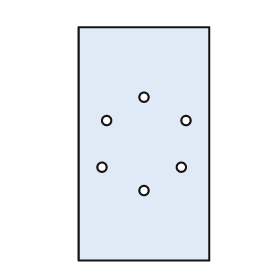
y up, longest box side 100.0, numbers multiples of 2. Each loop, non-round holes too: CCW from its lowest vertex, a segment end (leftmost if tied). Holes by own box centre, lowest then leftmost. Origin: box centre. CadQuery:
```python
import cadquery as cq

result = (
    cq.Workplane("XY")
    .moveTo(-28.0, -50.0)
    .lineTo(28.0, -50.0)
    .lineTo(28.0, 50.0)
    .lineTo(-28.0, 50.0)
    .close()
    .moveTo(0.0, -20.0)
    .circle(2.0)
    .moveTo(-18.0, -10.0)
    .circle(2.0)
    .moveTo(16.0, -10.0)
    .circle(2.0)
    .moveTo(-16.0, 10.0)
    .circle(2.0)
    .moveTo(18.0, 10.0)
    .circle(2.0)
    .moveTo(0.0, 20.0)
    .circle(2.0)
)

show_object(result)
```